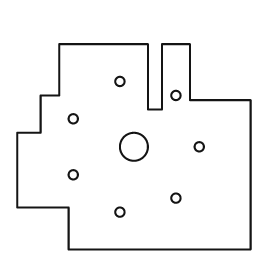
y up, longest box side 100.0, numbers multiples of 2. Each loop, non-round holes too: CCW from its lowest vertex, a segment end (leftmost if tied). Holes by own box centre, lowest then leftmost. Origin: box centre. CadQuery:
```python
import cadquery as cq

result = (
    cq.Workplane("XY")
    .moveTo(-28.0, -44.0)
    .lineTo(50.0, -44.0)
    .lineTo(50.0, 20.0)
    .lineTo(24.0, 20.0)
    .lineTo(24.0, 44.0)
    .lineTo(12.0, 44.0)
    .lineTo(12.0, 16.0)
    .lineTo(6.0, 16.0)
    .lineTo(6.0, 44.0)
    .lineTo(-32.0, 44.0)
    .lineTo(-32.0, 22.0)
    .lineTo(-40.0, 22.0)
    .lineTo(-40.0, 6.0)
    .lineTo(-50.0, 6.0)
    .lineTo(-50.0, -26.0)
    .lineTo(-28.0, -26.0)
    .close()
    .moveTo(-6.0, -28.0)
    .circle(2.0)
    .moveTo(18.0, -22.0)
    .circle(2.0)
    .moveTo(-26.0, -12.0)
    .circle(2.0)
    .moveTo(0.0, 0.0)
    .circle(6.0)
    .moveTo(28.0, 0.0)
    .circle(2.0)
    .moveTo(-26.0, 12.0)
    .circle(2.0)
    .moveTo(18.0, 22.0)
    .circle(2.0)
    .moveTo(-6.0, 28.0)
    .circle(2.0)
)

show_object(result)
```